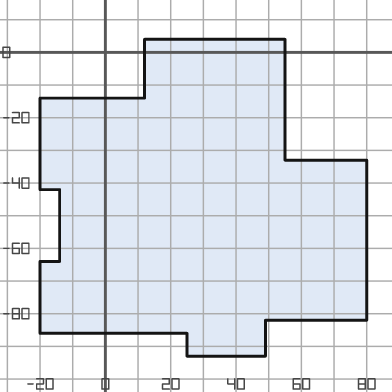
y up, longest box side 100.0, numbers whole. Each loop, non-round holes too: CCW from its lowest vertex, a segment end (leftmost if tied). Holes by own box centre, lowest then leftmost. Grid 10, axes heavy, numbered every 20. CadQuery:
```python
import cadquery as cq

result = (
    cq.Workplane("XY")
    .moveTo(25.0, -93.0)
    .lineTo(49.0, -93.0)
    .lineTo(49.0, -82.0)
    .lineTo(80.0, -82.0)
    .lineTo(80.0, -33.0)
    .lineTo(55.0, -33.0)
    .lineTo(55.0, 4.0)
    .lineTo(12.0, 4.0)
    .lineTo(12.0, -14.0)
    .lineTo(-20.0, -14.0)
    .lineTo(-20.0, -42.0)
    .lineTo(-14.0, -42.0)
    .lineTo(-14.0, -64.0)
    .lineTo(-20.0, -64.0)
    .lineTo(-20.0, -86.0)
    .lineTo(25.0, -86.0)
    .close()
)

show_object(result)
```